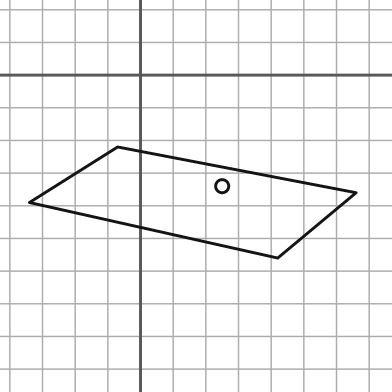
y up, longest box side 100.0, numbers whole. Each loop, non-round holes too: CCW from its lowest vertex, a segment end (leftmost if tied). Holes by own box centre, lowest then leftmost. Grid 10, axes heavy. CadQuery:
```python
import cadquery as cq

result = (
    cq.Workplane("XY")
    .moveTo(42.0, -56.0)
    .lineTo(66.0, -36.0)
    .lineTo(-7.0, -22.0)
    .lineTo(-34.0, -39.0)
    .close()
    .moveTo(25.0, -34.0)
    .circle(2.0)
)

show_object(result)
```